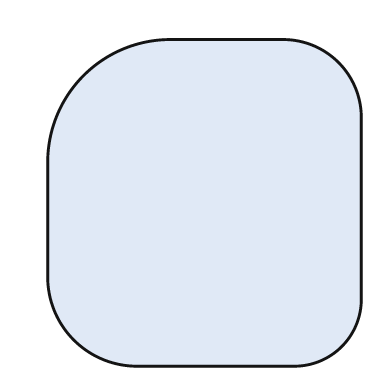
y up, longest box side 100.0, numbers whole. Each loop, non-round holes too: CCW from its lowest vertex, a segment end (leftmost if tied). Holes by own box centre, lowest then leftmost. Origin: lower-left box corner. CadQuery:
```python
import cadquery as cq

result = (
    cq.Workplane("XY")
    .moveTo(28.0, 0.0)
    .lineTo(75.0, 0.0)
    .threePointArc((90.0, 6.0), (96.0, 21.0))
    .lineTo(96.0, 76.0)
    .threePointArc((89.0, 93.0), (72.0, 100.0))
    .lineTo(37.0, 100.0)
    .threePointArc((11.0, 89.0), (0.0, 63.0))
    .lineTo(0.0, 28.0)
    .threePointArc((8.0, 8.0), (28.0, 0.0))
    .close()
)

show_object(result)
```